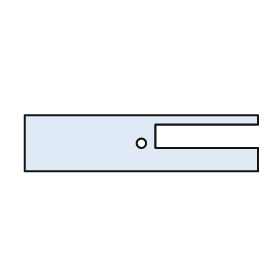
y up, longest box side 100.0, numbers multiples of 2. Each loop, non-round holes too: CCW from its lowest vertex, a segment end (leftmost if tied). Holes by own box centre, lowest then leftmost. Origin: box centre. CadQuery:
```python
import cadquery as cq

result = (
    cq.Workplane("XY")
    .moveTo(-50.0, -12.0)
    .lineTo(50.0, -12.0)
    .lineTo(50.0, -2.0)
    .lineTo(6.0, -2.0)
    .lineTo(6.0, 8.0)
    .lineTo(50.0, 8.0)
    .lineTo(50.0, 12.0)
    .lineTo(-50.0, 12.0)
    .close()
    .moveTo(0.0, 0.0)
    .circle(2.0)
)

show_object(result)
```